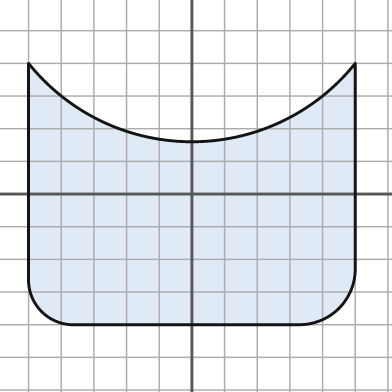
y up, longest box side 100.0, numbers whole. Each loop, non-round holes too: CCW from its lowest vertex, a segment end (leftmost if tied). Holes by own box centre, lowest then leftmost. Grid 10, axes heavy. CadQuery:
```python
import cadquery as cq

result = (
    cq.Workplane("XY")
    .moveTo(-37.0, -40.0)
    .lineTo(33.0, -40.0)
    .threePointArc((45.0, -35.0), (50.0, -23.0))
    .lineTo(50.0, 40.0)
    .threePointArc((0.0, 16.0), (-50.0, 40.0))
    .lineTo(-50.0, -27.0)
    .threePointArc((-46.0, -36.0), (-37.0, -40.0))
    .close()
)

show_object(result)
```